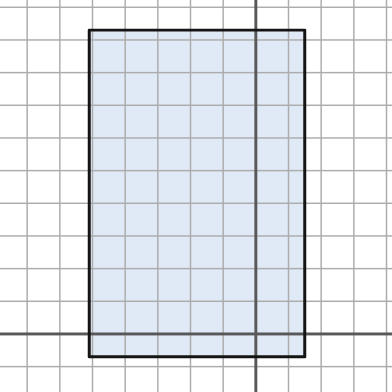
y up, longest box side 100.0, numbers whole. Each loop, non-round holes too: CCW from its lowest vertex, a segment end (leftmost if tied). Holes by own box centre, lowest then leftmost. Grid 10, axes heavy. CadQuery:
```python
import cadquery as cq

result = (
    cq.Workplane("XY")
    .moveTo(-51.0, -7.0)
    .lineTo(15.0, -7.0)
    .lineTo(15.0, 93.0)
    .lineTo(-51.0, 93.0)
    .close()
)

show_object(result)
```